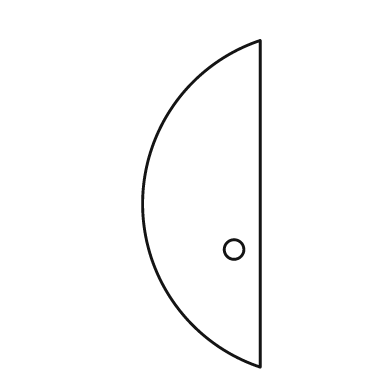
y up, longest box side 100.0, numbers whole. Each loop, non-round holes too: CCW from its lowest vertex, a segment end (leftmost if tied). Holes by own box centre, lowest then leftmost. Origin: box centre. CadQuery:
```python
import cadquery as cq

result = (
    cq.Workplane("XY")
    .moveTo(18.0, -50.0)
    .lineTo(18.0, 50.0)
    .threePointArc((-18.0, 0.0), (18.0, -50.0))
    .close()
    .moveTo(10.0, -14.0)
    .circle(3.0)
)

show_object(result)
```